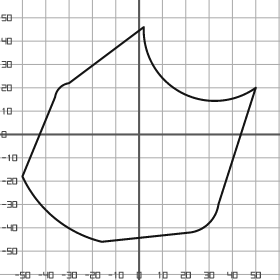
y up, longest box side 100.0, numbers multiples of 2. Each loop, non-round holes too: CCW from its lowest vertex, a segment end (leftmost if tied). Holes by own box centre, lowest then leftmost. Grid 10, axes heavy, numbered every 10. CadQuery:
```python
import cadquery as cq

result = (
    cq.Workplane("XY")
    .moveTo(-16.0, -46.0)
    .lineTo(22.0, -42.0)
    .threePointArc((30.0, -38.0), (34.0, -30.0))
    .lineTo(50.0, 20.0)
    .threePointArc((18.0, 18.0), (2.0, 46.0))
    .lineTo(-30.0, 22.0)
    .threePointArc((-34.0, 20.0), (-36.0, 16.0))
    .lineTo(-50.0, -18.0)
    .threePointArc((-36.0, -36.0), (-16.0, -46.0))
    .close()
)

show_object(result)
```